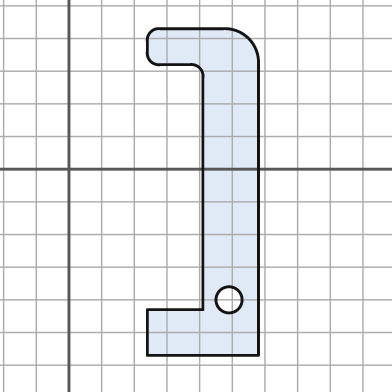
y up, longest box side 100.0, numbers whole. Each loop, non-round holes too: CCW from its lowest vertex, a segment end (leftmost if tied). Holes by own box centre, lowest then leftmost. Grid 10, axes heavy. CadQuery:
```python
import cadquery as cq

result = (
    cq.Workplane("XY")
    .moveTo(24.0, -57.0)
    .lineTo(58.0, -57.0)
    .lineTo(58.0, 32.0)
    .threePointArc((55.0, 40.0), (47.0, 43.0))
    .lineTo(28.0, 43.0)
    .threePointArc((25.0, 42.0), (24.0, 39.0))
    .lineTo(24.0, 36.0)
    .threePointArc((25.0, 33.0), (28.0, 32.0))
    .lineTo(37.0, 32.0)
    .threePointArc((40.0, 31.0), (41.0, 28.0))
    .lineTo(41.0, -43.0)
    .lineTo(24.0, -43.0)
    .close()
    .moveTo(49.0, -40.0)
    .circle(4.0)
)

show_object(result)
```